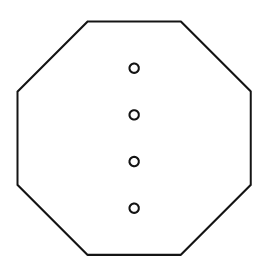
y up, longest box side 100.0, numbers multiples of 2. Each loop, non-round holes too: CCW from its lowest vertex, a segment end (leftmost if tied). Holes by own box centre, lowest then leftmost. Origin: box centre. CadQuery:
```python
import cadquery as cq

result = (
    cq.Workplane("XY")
    .moveTo(-20.0, -50.0)
    .lineTo(20.0, -50.0)
    .lineTo(50.0, -20.0)
    .lineTo(50.0, 20.0)
    .lineTo(20.0, 50.0)
    .lineTo(-20.0, 50.0)
    .lineTo(-50.0, 20.0)
    .lineTo(-50.0, -20.0)
    .close()
    .moveTo(0.0, -30.0)
    .circle(2.0)
    .moveTo(0.0, -10.0)
    .circle(2.0)
    .moveTo(0.0, 10.0)
    .circle(2.0)
    .moveTo(0.0, 30.0)
    .circle(2.0)
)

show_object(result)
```